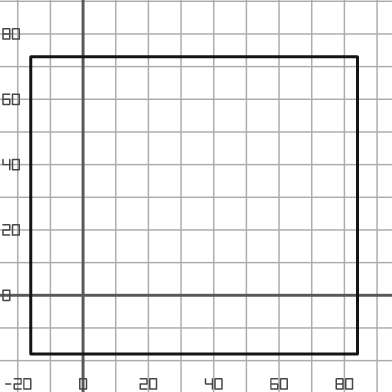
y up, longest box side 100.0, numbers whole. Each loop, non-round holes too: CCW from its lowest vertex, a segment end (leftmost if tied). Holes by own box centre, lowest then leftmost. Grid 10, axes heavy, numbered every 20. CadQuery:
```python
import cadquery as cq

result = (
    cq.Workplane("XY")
    .moveTo(-16.0, -18.0)
    .lineTo(84.0, -18.0)
    .lineTo(84.0, 73.0)
    .lineTo(-16.0, 73.0)
    .close()
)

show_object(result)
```